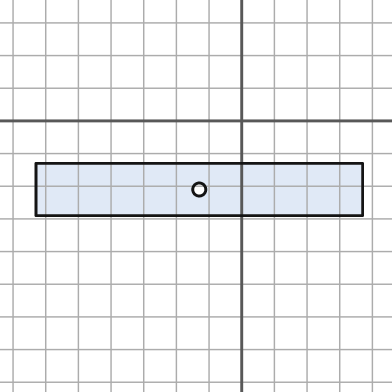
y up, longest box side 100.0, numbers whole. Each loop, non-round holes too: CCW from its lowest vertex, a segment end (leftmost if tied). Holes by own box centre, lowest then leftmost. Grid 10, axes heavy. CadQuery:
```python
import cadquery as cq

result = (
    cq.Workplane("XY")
    .moveTo(-63.0, -29.0)
    .lineTo(37.0, -29.0)
    .lineTo(37.0, -13.0)
    .lineTo(-63.0, -13.0)
    .close()
    .moveTo(-13.0, -21.0)
    .circle(2.0)
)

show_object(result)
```